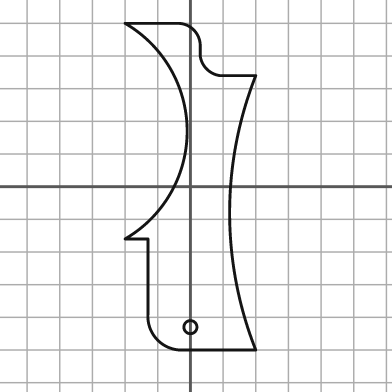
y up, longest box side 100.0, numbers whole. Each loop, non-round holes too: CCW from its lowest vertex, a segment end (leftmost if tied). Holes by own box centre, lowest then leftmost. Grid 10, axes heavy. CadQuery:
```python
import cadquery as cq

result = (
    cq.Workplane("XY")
    .moveTo(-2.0, -50.0)
    .lineTo(20.0, -50.0)
    .threePointArc((12.0, -8.0), (20.0, 34.0))
    .lineTo(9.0, 34.0)
    .threePointArc((5.0, 36.0), (3.0, 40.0))
    .lineTo(3.0, 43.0)
    .threePointArc((1.0, 48.0), (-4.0, 50.0))
    .lineTo(-20.0, 50.0)
    .threePointArc((-1.0, 17.0), (-20.0, -16.0))
    .lineTo(-13.0, -16.0)
    .lineTo(-13.0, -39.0)
    .threePointArc((-10.0, -47.0), (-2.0, -50.0))
    .close()
    .moveTo(0.0, -43.0)
    .circle(2.0)
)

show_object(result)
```